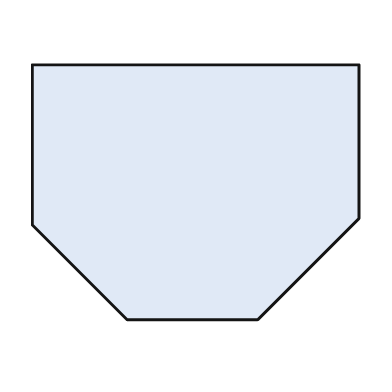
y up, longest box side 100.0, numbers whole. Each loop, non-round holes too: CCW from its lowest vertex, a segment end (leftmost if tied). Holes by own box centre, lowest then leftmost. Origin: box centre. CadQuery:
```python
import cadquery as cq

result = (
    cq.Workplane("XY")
    .moveTo(-21.0, -39.0)
    .lineTo(19.0, -39.0)
    .lineTo(50.0, -8.0)
    .lineTo(50.0, 39.0)
    .lineTo(-50.0, 39.0)
    .lineTo(-50.0, -10.0)
    .close()
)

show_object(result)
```